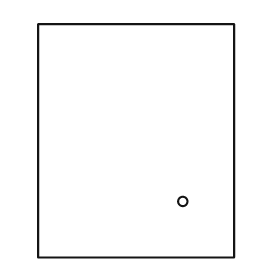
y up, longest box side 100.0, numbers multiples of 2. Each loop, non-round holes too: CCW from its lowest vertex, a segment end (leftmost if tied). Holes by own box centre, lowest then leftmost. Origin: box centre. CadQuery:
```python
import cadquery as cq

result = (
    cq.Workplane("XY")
    .moveTo(-42.0, -50.0)
    .lineTo(42.0, -50.0)
    .lineTo(42.0, 50.0)
    .lineTo(-42.0, 50.0)
    .close()
    .moveTo(20.0, -26.0)
    .circle(2.0)
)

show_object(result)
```